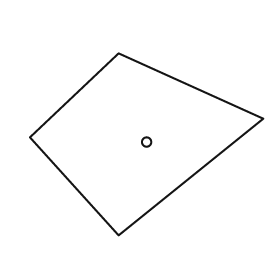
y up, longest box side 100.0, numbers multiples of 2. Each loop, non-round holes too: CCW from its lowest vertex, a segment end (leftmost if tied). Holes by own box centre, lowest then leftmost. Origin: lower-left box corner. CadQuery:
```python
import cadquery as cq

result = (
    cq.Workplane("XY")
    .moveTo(38.0, 0.0)
    .lineTo(100.0, 50.0)
    .lineTo(38.0, 78.0)
    .lineTo(0.0, 42.0)
    .close()
    .moveTo(50.0, 40.0)
    .circle(2.0)
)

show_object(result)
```